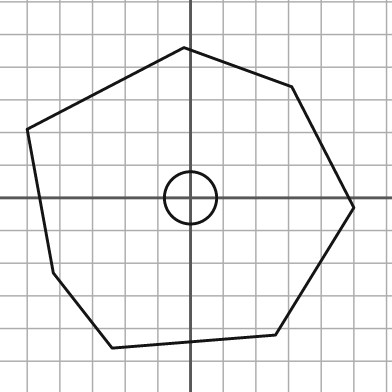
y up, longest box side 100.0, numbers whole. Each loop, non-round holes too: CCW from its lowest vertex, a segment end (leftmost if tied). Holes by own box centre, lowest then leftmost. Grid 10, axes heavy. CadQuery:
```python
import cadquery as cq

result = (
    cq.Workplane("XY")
    .moveTo(-24.0, -46.0)
    .lineTo(26.0, -42.0)
    .lineTo(50.0, -3.0)
    .lineTo(31.0, 34.0)
    .lineTo(-2.0, 46.0)
    .lineTo(-50.0, 21.0)
    .lineTo(-42.0, -23.0)
    .close()
    .moveTo(0.0, 0.0)
    .circle(8.0)
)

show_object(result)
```